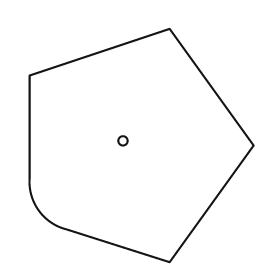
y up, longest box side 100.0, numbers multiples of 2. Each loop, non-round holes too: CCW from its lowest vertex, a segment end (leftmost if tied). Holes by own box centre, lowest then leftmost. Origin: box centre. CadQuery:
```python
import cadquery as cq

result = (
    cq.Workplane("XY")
    .moveTo(12.0, -50.0)
    .lineTo(48.0, 0.0)
    .lineTo(12.0, 50.0)
    .lineTo(-48.0, 30.0)
    .lineTo(-48.0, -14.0)
    .threePointArc((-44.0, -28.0), (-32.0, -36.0))
    .close()
    .moveTo(-8.0, 2.0)
    .circle(2.0)
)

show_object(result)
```